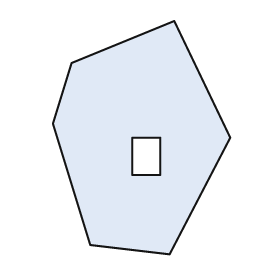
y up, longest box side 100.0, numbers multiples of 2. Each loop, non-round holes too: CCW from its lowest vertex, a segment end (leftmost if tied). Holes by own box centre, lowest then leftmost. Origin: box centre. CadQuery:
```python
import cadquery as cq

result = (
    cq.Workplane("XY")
    .moveTo(12.0, -50.0)
    .lineTo(38.0, 0.0)
    .lineTo(14.0, 50.0)
    .lineTo(-30.0, 32.0)
    .lineTo(-38.0, 6.0)
    .lineTo(-22.0, -46.0)
    .close()
    .moveTo(-4.0, -16.0)
    .lineTo(8.0, -16.0)
    .lineTo(8.0, 0.0)
    .lineTo(-4.0, 0.0)
    .close()
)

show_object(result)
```